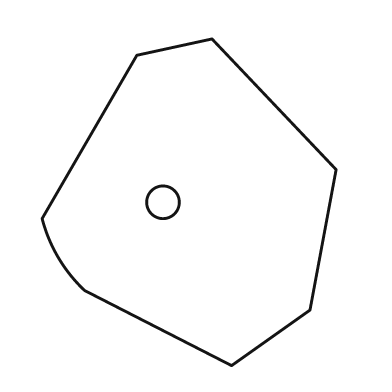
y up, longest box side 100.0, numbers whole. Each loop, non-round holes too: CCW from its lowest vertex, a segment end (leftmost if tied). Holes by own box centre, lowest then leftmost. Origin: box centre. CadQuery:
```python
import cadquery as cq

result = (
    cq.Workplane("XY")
    .moveTo(13.0, -50.0)
    .lineTo(37.0, -33.0)
    .lineTo(45.0, 10.0)
    .lineTo(7.0, 50.0)
    .lineTo(-16.0, 45.0)
    .lineTo(-45.0, -5.0)
    .threePointArc((-40.0, -17.0), (-32.0, -27.0))
    .close()
    .moveTo(-8.0, 0.0)
    .circle(5.0)
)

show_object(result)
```